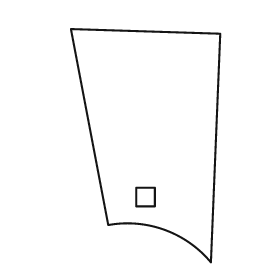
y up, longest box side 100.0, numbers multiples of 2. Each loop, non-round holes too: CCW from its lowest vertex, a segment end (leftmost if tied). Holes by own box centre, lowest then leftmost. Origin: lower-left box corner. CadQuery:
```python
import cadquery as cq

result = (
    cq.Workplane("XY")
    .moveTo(60.0, 0.0)
    .lineTo(64.0, 98.0)
    .lineTo(0.0, 100.0)
    .lineTo(16.0, 16.0)
    .threePointArc((40.0, 14.0), (60.0, 0.0))
    .close()
    .moveTo(28.0, 24.0)
    .lineTo(36.0, 24.0)
    .lineTo(36.0, 32.0)
    .lineTo(28.0, 32.0)
    .close()
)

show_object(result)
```